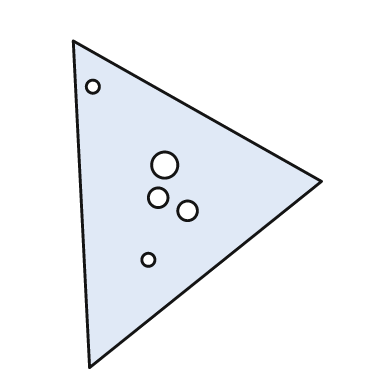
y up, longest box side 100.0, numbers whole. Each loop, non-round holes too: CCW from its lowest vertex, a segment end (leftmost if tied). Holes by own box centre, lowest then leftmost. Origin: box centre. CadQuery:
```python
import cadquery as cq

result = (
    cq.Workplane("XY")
    .moveTo(-33.0, -50.0)
    .lineTo(38.0, 7.0)
    .lineTo(-38.0, 50.0)
    .close()
    .moveTo(-15.0, -17.0)
    .circle(2.0)
    .moveTo(-3.0, -2.0)
    .circle(3.0)
    .moveTo(-12.0, 2.0)
    .circle(3.0)
    .moveTo(-10.0, 12.0)
    .circle(4.0)
    .moveTo(-32.0, 36.0)
    .circle(2.0)
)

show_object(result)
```